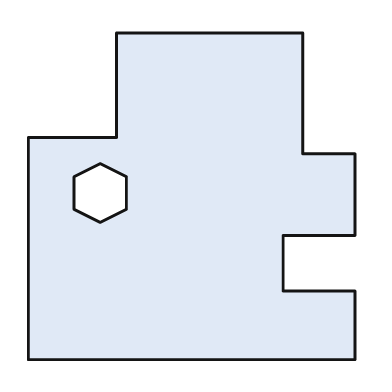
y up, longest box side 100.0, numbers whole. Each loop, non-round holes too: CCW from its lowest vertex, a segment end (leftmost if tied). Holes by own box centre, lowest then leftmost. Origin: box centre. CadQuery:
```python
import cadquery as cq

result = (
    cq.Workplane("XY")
    .moveTo(-50.0, -50.0)
    .lineTo(50.0, -50.0)
    .lineTo(50.0, -29.0)
    .lineTo(28.0, -29.0)
    .lineTo(28.0, -12.0)
    .lineTo(50.0, -12.0)
    .lineTo(50.0, 13.0)
    .lineTo(34.0, 13.0)
    .lineTo(34.0, 50.0)
    .lineTo(-23.0, 50.0)
    .lineTo(-23.0, 18.0)
    .lineTo(-50.0, 18.0)
    .close()
    .moveTo(-28.0, -8.0)
    .lineTo(-20.0, -4.0)
    .lineTo(-20.0, 6.0)
    .lineTo(-28.0, 10.0)
    .lineTo(-36.0, 6.0)
    .lineTo(-36.0, -4.0)
    .close()
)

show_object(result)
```